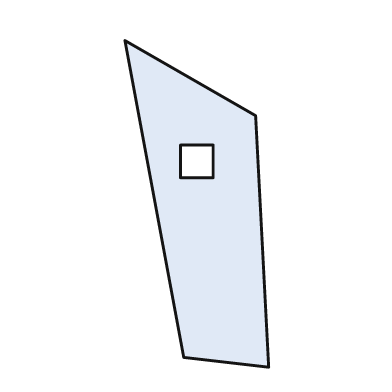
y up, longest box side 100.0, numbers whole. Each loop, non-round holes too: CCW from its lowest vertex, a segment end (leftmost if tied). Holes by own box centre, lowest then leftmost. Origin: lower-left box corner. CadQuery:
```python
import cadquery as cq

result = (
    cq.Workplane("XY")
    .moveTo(44.0, 0.0)
    .lineTo(40.0, 77.0)
    .lineTo(0.0, 100.0)
    .lineTo(18.0, 3.0)
    .close()
    .moveTo(17.0, 58.0)
    .lineTo(27.0, 58.0)
    .lineTo(27.0, 68.0)
    .lineTo(17.0, 68.0)
    .close()
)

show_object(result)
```